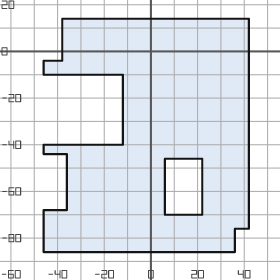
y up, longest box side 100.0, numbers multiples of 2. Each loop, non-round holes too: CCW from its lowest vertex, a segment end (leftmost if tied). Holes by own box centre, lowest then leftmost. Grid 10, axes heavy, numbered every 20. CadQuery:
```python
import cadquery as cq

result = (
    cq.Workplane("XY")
    .moveTo(-46.0, -86.0)
    .lineTo(36.0, -86.0)
    .lineTo(36.0, -76.0)
    .lineTo(42.0, -76.0)
    .lineTo(42.0, 14.0)
    .lineTo(-38.0, 14.0)
    .lineTo(-38.0, -4.0)
    .lineTo(-46.0, -4.0)
    .lineTo(-46.0, -10.0)
    .lineTo(-12.0, -10.0)
    .lineTo(-12.0, -40.0)
    .lineTo(-46.0, -40.0)
    .lineTo(-46.0, -44.0)
    .lineTo(-36.0, -44.0)
    .lineTo(-36.0, -68.0)
    .lineTo(-46.0, -68.0)
    .close()
    .moveTo(6.0, -70.0)
    .lineTo(22.0, -70.0)
    .lineTo(22.0, -46.0)
    .lineTo(6.0, -46.0)
    .close()
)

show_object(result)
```